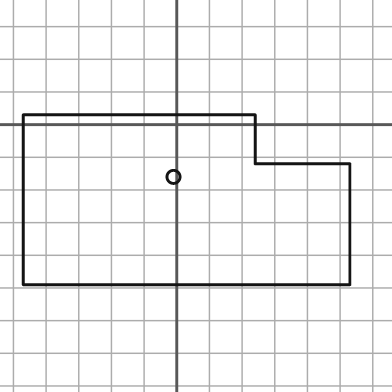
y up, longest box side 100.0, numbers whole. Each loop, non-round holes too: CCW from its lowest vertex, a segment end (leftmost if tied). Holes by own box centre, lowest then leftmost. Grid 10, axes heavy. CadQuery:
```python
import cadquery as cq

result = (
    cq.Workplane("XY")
    .moveTo(-47.0, -49.0)
    .lineTo(53.0, -49.0)
    .lineTo(53.0, -12.0)
    .lineTo(24.0, -12.0)
    .lineTo(24.0, 3.0)
    .lineTo(-47.0, 3.0)
    .close()
    .moveTo(-1.0, -16.0)
    .circle(2.0)
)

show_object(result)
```